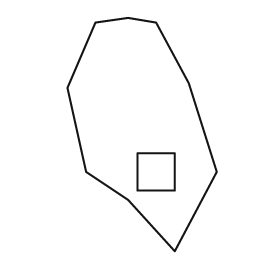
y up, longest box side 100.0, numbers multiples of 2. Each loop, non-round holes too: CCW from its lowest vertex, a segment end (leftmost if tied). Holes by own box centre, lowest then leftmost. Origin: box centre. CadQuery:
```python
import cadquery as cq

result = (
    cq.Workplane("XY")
    .moveTo(14.0, -50.0)
    .lineTo(32.0, -16.0)
    .lineTo(20.0, 22.0)
    .lineTo(6.0, 48.0)
    .lineTo(-6.0, 50.0)
    .lineTo(-20.0, 48.0)
    .lineTo(-32.0, 20.0)
    .lineTo(-24.0, -16.0)
    .lineTo(-6.0, -28.0)
    .close()
    .moveTo(-2.0, -24.0)
    .lineTo(14.0, -24.0)
    .lineTo(14.0, -8.0)
    .lineTo(-2.0, -8.0)
    .close()
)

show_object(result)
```